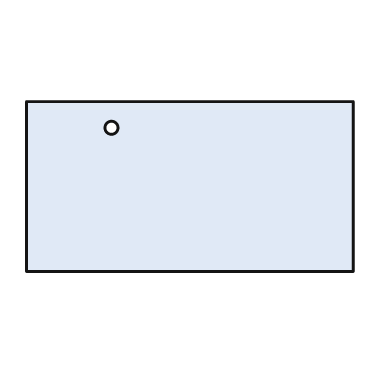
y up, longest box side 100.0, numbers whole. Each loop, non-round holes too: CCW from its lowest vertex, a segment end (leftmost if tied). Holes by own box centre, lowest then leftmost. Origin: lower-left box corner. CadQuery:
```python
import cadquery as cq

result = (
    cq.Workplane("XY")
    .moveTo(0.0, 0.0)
    .lineTo(100.0, 0.0)
    .lineTo(100.0, 52.0)
    .lineTo(0.0, 52.0)
    .close()
    .moveTo(26.0, 44.0)
    .circle(2.0)
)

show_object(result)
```